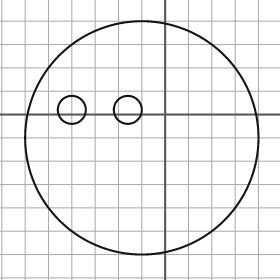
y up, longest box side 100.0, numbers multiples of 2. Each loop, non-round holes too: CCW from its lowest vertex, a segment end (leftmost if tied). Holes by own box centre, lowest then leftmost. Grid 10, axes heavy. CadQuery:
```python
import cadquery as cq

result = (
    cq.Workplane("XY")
    .moveTo(-10.0, -10.0)
    .circle(50.0)
    .moveTo(-40.0, 2.0)
    .circle(6.0)
    .moveTo(-16.0, 2.0)
    .circle(6.0)
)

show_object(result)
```